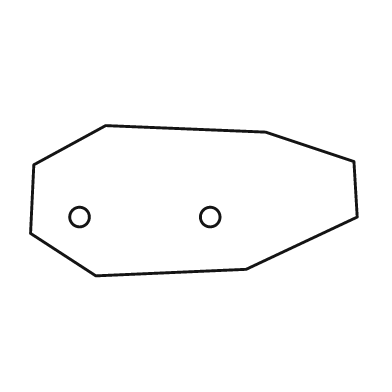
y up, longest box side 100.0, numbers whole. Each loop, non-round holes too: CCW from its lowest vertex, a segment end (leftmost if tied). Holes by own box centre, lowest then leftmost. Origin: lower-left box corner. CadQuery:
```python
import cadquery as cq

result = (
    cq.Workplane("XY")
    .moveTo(20.0, 0.0)
    .lineTo(66.0, 2.0)
    .lineTo(100.0, 18.0)
    .lineTo(99.0, 35.0)
    .lineTo(72.0, 44.0)
    .lineTo(23.0, 46.0)
    .lineTo(1.0, 34.0)
    .lineTo(0.0, 13.0)
    .close()
    .moveTo(15.0, 18.0)
    .circle(3.0)
    .moveTo(55.0, 18.0)
    .circle(3.0)
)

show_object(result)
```